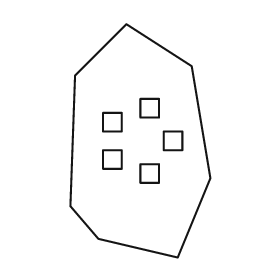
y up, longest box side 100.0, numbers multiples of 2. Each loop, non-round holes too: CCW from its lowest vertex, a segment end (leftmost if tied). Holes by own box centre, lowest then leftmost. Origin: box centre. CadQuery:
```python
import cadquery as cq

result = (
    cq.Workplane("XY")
    .moveTo(16.0, -50.0)
    .lineTo(30.0, -16.0)
    .lineTo(22.0, 32.0)
    .lineTo(-6.0, 50.0)
    .lineTo(-28.0, 28.0)
    .lineTo(-30.0, -28.0)
    .lineTo(-18.0, -42.0)
    .close()
    .moveTo(0.0, -18.0)
    .lineTo(8.0, -18.0)
    .lineTo(8.0, -10.0)
    .lineTo(0.0, -10.0)
    .close()
    .moveTo(-16.0, -12.0)
    .lineTo(-8.0, -12.0)
    .lineTo(-8.0, -4.0)
    .lineTo(-16.0, -4.0)
    .close()
    .moveTo(10.0, -4.0)
    .lineTo(18.0, -4.0)
    .lineTo(18.0, 4.0)
    .lineTo(10.0, 4.0)
    .close()
    .moveTo(-16.0, 4.0)
    .lineTo(-8.0, 4.0)
    .lineTo(-8.0, 12.0)
    .lineTo(-16.0, 12.0)
    .close()
    .moveTo(0.0, 10.0)
    .lineTo(8.0, 10.0)
    .lineTo(8.0, 18.0)
    .lineTo(0.0, 18.0)
    .close()
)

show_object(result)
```